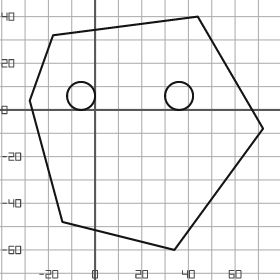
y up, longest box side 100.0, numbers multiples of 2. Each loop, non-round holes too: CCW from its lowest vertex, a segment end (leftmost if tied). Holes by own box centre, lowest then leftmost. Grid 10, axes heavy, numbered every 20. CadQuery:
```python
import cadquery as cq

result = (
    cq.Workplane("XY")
    .moveTo(34.0, -60.0)
    .lineTo(72.0, -8.0)
    .lineTo(44.0, 40.0)
    .lineTo(-18.0, 32.0)
    .lineTo(-28.0, 4.0)
    .lineTo(-14.0, -48.0)
    .close()
    .moveTo(-6.0, 6.0)
    .circle(6.0)
    .moveTo(36.0, 6.0)
    .circle(6.0)
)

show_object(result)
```